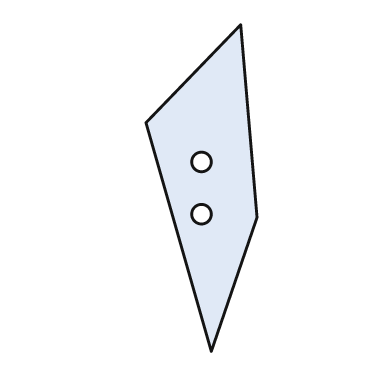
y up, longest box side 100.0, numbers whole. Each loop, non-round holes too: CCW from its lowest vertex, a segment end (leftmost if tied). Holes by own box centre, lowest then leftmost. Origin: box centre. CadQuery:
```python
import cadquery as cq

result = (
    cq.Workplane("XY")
    .moveTo(3.0, -50.0)
    .lineTo(17.0, -9.0)
    .lineTo(12.0, 50.0)
    .lineTo(-17.0, 20.0)
    .close()
    .moveTo(0.0, -8.0)
    .circle(3.0)
    .moveTo(0.0, 8.0)
    .circle(3.0)
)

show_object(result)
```